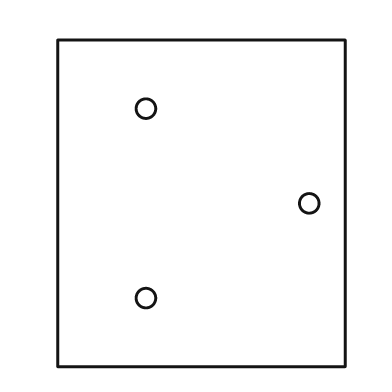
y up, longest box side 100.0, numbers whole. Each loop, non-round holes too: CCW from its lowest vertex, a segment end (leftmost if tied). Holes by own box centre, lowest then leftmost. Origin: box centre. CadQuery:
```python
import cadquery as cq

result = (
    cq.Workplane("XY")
    .moveTo(-44.0, -50.0)
    .lineTo(44.0, -50.0)
    .lineTo(44.0, 50.0)
    .lineTo(-44.0, 50.0)
    .close()
    .moveTo(-17.0, -29.0)
    .circle(3.0)
    .moveTo(33.0, 0.0)
    .circle(3.0)
    .moveTo(-17.0, 29.0)
    .circle(3.0)
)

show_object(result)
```